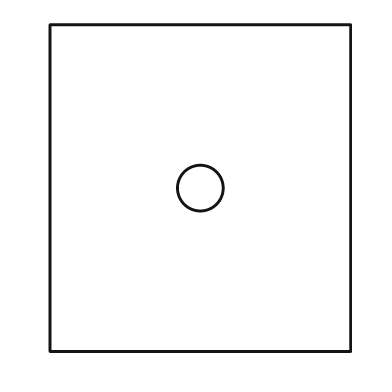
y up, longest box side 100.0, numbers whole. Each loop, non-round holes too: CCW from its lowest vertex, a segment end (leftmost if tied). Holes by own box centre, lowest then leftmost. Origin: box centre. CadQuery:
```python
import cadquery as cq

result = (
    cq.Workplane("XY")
    .moveTo(-46.0, -50.0)
    .lineTo(46.0, -50.0)
    .lineTo(46.0, 50.0)
    .lineTo(-46.0, 50.0)
    .close()
    .moveTo(0.0, 0.0)
    .circle(7.0)
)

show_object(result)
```